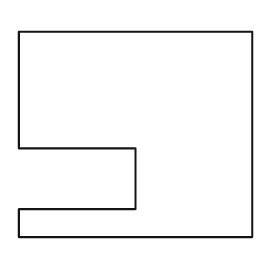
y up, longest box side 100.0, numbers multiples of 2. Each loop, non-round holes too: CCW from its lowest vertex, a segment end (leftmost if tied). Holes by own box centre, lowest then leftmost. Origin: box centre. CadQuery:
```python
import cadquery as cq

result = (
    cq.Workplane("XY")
    .moveTo(-50.0, -44.0)
    .lineTo(50.0, -44.0)
    .lineTo(50.0, 44.0)
    .lineTo(-50.0, 44.0)
    .lineTo(-50.0, -6.0)
    .lineTo(0.0, -6.0)
    .lineTo(0.0, -32.0)
    .lineTo(-50.0, -32.0)
    .close()
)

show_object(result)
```